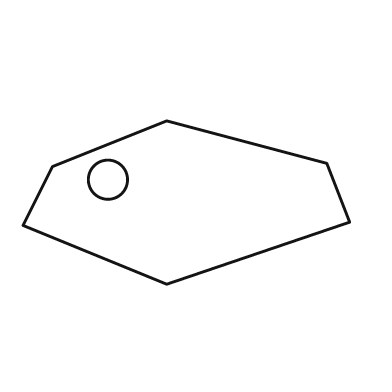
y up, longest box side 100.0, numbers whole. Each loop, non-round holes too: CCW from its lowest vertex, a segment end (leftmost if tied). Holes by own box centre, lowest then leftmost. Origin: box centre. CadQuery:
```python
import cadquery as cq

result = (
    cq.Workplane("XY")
    .moveTo(-6.0, -25.0)
    .lineTo(50.0, -6.0)
    .lineTo(43.0, 12.0)
    .lineTo(-6.0, 25.0)
    .lineTo(-41.0, 11.0)
    .lineTo(-50.0, -7.0)
    .close()
    .moveTo(-24.0, 7.0)
    .circle(6.0)
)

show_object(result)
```